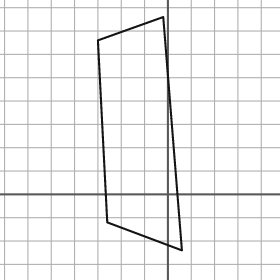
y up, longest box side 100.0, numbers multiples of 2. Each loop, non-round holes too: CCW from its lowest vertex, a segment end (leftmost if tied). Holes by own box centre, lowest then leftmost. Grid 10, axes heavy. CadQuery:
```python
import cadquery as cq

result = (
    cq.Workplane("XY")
    .moveTo(6.0, -24.0)
    .lineTo(-2.0, 76.0)
    .lineTo(-30.0, 66.0)
    .lineTo(-26.0, -12.0)
    .close()
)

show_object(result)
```